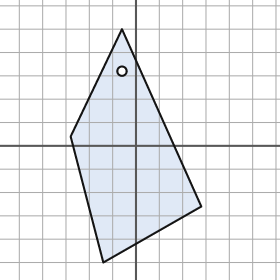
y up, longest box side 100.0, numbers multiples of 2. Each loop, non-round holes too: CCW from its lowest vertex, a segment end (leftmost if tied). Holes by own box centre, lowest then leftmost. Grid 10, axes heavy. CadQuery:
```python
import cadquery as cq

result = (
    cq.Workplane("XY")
    .moveTo(-14.0, -50.0)
    .lineTo(28.0, -26.0)
    .lineTo(-6.0, 50.0)
    .lineTo(-28.0, 4.0)
    .close()
    .moveTo(-6.0, 32.0)
    .circle(2.0)
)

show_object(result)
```